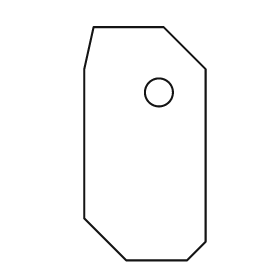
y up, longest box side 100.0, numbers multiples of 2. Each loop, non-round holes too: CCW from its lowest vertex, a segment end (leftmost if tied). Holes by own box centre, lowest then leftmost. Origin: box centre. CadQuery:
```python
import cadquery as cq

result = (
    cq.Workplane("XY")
    .moveTo(-8.0, -50.0)
    .lineTo(18.0, -50.0)
    .lineTo(26.0, -42.0)
    .lineTo(26.0, 32.0)
    .lineTo(8.0, 50.0)
    .lineTo(-22.0, 50.0)
    .lineTo(-26.0, 32.0)
    .lineTo(-26.0, -32.0)
    .close()
    .moveTo(6.0, 22.0)
    .circle(6.0)
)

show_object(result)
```